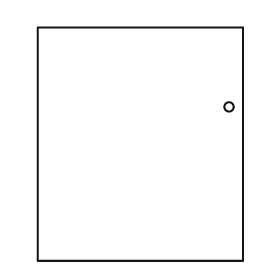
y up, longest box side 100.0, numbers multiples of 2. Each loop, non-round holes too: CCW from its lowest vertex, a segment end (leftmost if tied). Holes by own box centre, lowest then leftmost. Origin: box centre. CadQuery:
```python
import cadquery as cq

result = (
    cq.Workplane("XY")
    .moveTo(-44.0, -50.0)
    .lineTo(44.0, -50.0)
    .lineTo(44.0, 50.0)
    .lineTo(-44.0, 50.0)
    .close()
    .moveTo(38.0, 16.0)
    .circle(2.0)
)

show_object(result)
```